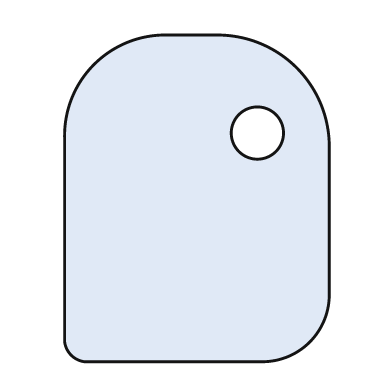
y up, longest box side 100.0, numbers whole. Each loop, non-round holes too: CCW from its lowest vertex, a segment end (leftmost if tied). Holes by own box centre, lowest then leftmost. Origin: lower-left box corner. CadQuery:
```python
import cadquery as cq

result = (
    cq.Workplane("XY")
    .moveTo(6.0, 0.0)
    .lineTo(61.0, 0.0)
    .threePointArc((75.0, 6.0), (81.0, 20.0))
    .lineTo(81.0, 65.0)
    .threePointArc((71.0, 90.0), (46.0, 100.0))
    .lineTo(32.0, 100.0)
    .threePointArc((9.0, 91.0), (0.0, 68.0))
    .lineTo(0.0, 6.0)
    .threePointArc((2.0, 2.0), (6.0, 0.0))
    .close()
    .moveTo(59.0, 70.0)
    .circle(8.0)
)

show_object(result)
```